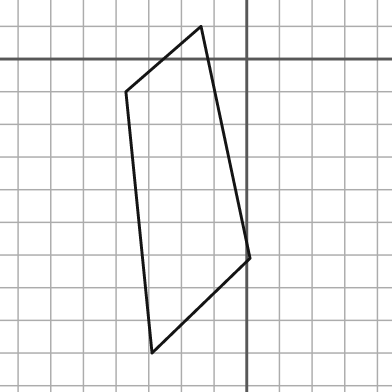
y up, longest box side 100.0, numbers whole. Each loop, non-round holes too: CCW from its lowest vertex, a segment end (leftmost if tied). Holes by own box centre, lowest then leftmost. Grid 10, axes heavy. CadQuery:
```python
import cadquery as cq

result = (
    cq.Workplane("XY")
    .moveTo(-29.0, -90.0)
    .lineTo(1.0, -61.0)
    .lineTo(-14.0, 10.0)
    .lineTo(-37.0, -10.0)
    .close()
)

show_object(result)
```